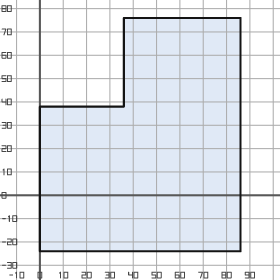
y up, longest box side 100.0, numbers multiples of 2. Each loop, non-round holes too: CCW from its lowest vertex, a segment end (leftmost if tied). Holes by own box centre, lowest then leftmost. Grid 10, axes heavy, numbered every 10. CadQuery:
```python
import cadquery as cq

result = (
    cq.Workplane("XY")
    .moveTo(0.0, -24.0)
    .lineTo(86.0, -24.0)
    .lineTo(86.0, 76.0)
    .lineTo(36.0, 76.0)
    .lineTo(36.0, 38.0)
    .lineTo(0.0, 38.0)
    .close()
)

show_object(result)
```